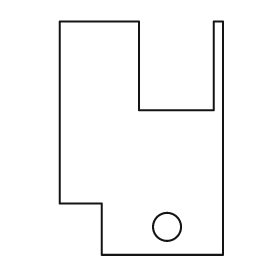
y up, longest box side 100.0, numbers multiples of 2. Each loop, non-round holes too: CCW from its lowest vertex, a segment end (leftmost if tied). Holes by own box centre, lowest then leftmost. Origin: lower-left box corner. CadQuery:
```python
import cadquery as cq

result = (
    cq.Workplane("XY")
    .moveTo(18.0, 0.0)
    .lineTo(70.0, 0.0)
    .lineTo(70.0, 100.0)
    .lineTo(66.0, 100.0)
    .lineTo(66.0, 62.0)
    .lineTo(34.0, 62.0)
    .lineTo(34.0, 100.0)
    .lineTo(0.0, 100.0)
    .lineTo(0.0, 22.0)
    .lineTo(18.0, 22.0)
    .close()
    .moveTo(46.0, 12.0)
    .circle(6.0)
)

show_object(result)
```